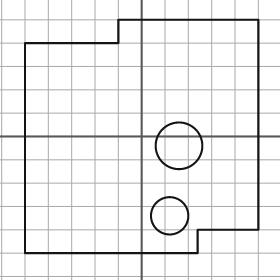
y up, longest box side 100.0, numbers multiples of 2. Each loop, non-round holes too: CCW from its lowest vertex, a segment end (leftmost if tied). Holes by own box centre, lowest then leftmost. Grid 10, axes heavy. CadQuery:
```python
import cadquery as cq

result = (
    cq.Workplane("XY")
    .moveTo(-50.0, -50.0)
    .lineTo(24.0, -50.0)
    .lineTo(24.0, -40.0)
    .lineTo(50.0, -40.0)
    .lineTo(50.0, 50.0)
    .lineTo(-10.0, 50.0)
    .lineTo(-10.0, 40.0)
    .lineTo(-50.0, 40.0)
    .close()
    .moveTo(12.0, -34.0)
    .circle(8.0)
    .moveTo(16.0, -4.0)
    .circle(10.0)
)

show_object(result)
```